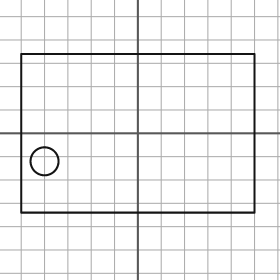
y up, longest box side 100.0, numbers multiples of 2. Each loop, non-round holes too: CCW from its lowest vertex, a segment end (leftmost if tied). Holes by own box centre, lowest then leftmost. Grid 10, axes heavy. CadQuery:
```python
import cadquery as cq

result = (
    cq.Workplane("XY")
    .moveTo(-50.0, -34.0)
    .lineTo(50.0, -34.0)
    .lineTo(50.0, 34.0)
    .lineTo(-50.0, 34.0)
    .close()
    .moveTo(-40.0, -12.0)
    .circle(6.0)
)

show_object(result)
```